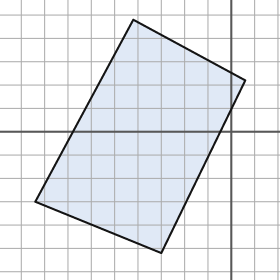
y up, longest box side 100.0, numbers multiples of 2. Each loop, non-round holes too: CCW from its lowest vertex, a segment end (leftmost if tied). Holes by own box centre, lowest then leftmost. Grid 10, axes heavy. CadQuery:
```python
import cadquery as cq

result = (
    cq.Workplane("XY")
    .moveTo(-30.0, -52.0)
    .lineTo(6.0, 22.0)
    .lineTo(-42.0, 48.0)
    .lineTo(-84.0, -30.0)
    .close()
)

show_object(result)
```